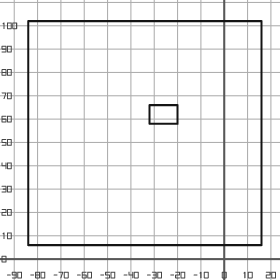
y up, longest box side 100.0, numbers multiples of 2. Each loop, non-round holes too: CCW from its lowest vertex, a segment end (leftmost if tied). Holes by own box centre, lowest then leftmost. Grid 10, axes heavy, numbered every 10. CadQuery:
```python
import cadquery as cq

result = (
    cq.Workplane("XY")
    .moveTo(-84.0, 6.0)
    .lineTo(16.0, 6.0)
    .lineTo(16.0, 102.0)
    .lineTo(-84.0, 102.0)
    .close()
    .moveTo(-32.0, 58.0)
    .lineTo(-20.0, 58.0)
    .lineTo(-20.0, 66.0)
    .lineTo(-32.0, 66.0)
    .close()
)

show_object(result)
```